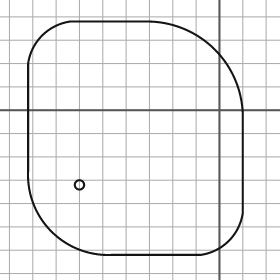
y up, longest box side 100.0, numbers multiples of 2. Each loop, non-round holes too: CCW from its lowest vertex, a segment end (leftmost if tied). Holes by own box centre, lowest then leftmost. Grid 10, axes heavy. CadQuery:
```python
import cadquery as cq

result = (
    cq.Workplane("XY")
    .moveTo(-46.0, -62.0)
    .lineTo(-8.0, -62.0)
    .threePointArc((4.0, -56.0), (10.0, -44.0))
    .lineTo(10.0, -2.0)
    .threePointArc((-2.0, 26.0), (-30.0, 38.0))
    .lineTo(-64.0, 38.0)
    .threePointArc((-76.0, 32.0), (-82.0, 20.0))
    .lineTo(-82.0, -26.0)
    .threePointArc((-72.0, -52.0), (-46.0, -62.0))
    .close()
    .moveTo(-60.0, -32.0)
    .circle(2.0)
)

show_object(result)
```